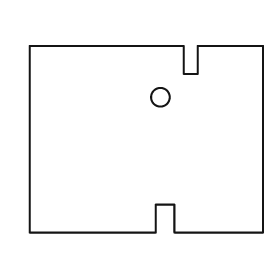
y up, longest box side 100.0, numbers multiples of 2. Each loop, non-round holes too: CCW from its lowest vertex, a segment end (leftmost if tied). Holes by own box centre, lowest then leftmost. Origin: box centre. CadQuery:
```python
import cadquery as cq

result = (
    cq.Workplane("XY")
    .moveTo(-50.0, -40.0)
    .lineTo(4.0, -40.0)
    .lineTo(4.0, -28.0)
    .lineTo(12.0, -28.0)
    .lineTo(12.0, -40.0)
    .lineTo(50.0, -40.0)
    .lineTo(50.0, 40.0)
    .lineTo(22.0, 40.0)
    .lineTo(22.0, 28.0)
    .lineTo(16.0, 28.0)
    .lineTo(16.0, 40.0)
    .lineTo(-50.0, 40.0)
    .close()
    .moveTo(6.0, 18.0)
    .circle(4.0)
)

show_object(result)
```